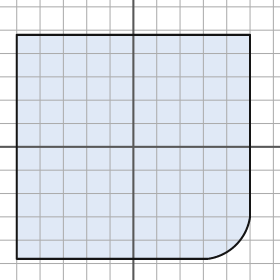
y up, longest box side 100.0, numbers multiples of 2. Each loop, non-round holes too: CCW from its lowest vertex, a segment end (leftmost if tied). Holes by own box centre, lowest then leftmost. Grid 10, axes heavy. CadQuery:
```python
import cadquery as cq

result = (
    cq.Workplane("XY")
    .moveTo(-50.0, -48.0)
    .lineTo(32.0, -48.0)
    .threePointArc((44.0, -42.0), (50.0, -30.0))
    .lineTo(50.0, 48.0)
    .lineTo(-50.0, 48.0)
    .close()
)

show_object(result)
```